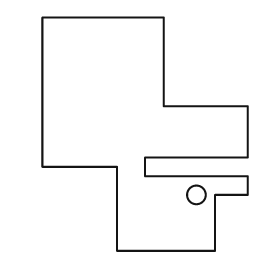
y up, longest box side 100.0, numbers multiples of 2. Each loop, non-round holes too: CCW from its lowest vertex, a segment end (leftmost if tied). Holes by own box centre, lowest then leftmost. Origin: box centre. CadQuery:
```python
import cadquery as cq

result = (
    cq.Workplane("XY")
    .moveTo(-12.0, -50.0)
    .lineTo(30.0, -50.0)
    .lineTo(30.0, -26.0)
    .lineTo(44.0, -26.0)
    .lineTo(44.0, -18.0)
    .lineTo(0.0, -18.0)
    .lineTo(0.0, -10.0)
    .lineTo(44.0, -10.0)
    .lineTo(44.0, 12.0)
    .lineTo(8.0, 12.0)
    .lineTo(8.0, 50.0)
    .lineTo(-44.0, 50.0)
    .lineTo(-44.0, -14.0)
    .lineTo(-12.0, -14.0)
    .close()
    .moveTo(22.0, -26.0)
    .circle(4.0)
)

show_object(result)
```